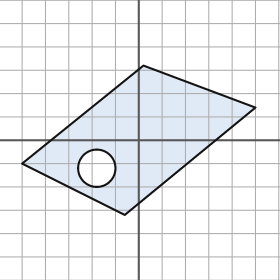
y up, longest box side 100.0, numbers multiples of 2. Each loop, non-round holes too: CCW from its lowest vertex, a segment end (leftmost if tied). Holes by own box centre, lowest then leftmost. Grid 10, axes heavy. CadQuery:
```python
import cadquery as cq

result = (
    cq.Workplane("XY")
    .moveTo(-6.0, -32.0)
    .lineTo(50.0, 14.0)
    .lineTo(2.0, 32.0)
    .lineTo(-50.0, -10.0)
    .close()
    .moveTo(-18.0, -12.0)
    .circle(8.0)
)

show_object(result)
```